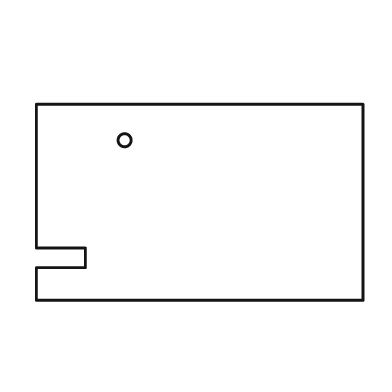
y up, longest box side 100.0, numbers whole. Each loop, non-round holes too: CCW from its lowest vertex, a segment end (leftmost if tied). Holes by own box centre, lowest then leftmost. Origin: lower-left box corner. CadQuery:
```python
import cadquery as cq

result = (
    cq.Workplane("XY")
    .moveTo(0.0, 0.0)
    .lineTo(100.0, 0.0)
    .lineTo(100.0, 60.0)
    .lineTo(0.0, 60.0)
    .lineTo(0.0, 16.0)
    .lineTo(15.0, 16.0)
    .lineTo(15.0, 10.0)
    .lineTo(0.0, 10.0)
    .close()
    .moveTo(27.0, 49.0)
    .circle(2.0)
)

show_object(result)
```